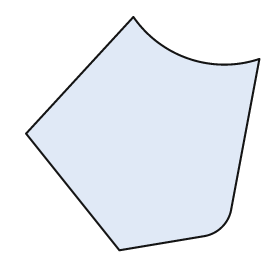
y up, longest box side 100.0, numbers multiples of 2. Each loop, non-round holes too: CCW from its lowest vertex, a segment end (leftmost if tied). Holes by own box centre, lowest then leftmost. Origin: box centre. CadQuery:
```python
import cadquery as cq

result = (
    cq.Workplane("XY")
    .moveTo(-10.0, -50.0)
    .lineTo(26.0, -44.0)
    .threePointArc((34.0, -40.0), (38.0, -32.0))
    .lineTo(50.0, 32.0)
    .threePointArc((20.0, 32.0), (-4.0, 50.0))
    .lineTo(-50.0, 0.0)
    .close()
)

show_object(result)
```